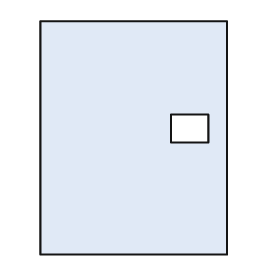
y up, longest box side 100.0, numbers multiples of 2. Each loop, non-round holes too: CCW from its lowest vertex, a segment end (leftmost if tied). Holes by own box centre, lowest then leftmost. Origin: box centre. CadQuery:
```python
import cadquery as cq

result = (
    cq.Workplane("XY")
    .moveTo(-40.0, -50.0)
    .lineTo(40.0, -50.0)
    .lineTo(40.0, 50.0)
    .lineTo(-40.0, 50.0)
    .close()
    .moveTo(16.0, -2.0)
    .lineTo(32.0, -2.0)
    .lineTo(32.0, 10.0)
    .lineTo(16.0, 10.0)
    .close()
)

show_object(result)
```